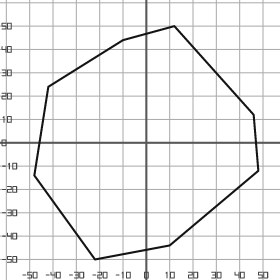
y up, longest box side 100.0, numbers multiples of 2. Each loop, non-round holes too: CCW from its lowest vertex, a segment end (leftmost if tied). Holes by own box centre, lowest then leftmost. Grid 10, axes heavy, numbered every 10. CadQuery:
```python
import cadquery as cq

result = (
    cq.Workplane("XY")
    .moveTo(-22.0, -50.0)
    .lineTo(10.0, -44.0)
    .lineTo(48.0, -12.0)
    .lineTo(46.0, 12.0)
    .lineTo(12.0, 50.0)
    .lineTo(-10.0, 44.0)
    .lineTo(-42.0, 24.0)
    .lineTo(-48.0, -14.0)
    .close()
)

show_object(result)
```